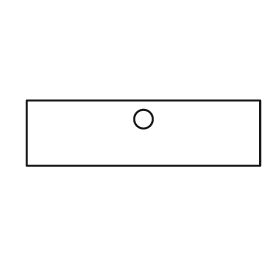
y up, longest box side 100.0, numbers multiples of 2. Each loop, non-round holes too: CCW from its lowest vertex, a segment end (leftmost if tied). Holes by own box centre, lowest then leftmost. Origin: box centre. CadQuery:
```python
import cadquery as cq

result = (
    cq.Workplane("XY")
    .moveTo(-50.0, -14.0)
    .lineTo(50.0, -14.0)
    .lineTo(50.0, 14.0)
    .lineTo(-50.0, 14.0)
    .close()
    .moveTo(0.0, 6.0)
    .circle(4.0)
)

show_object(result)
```